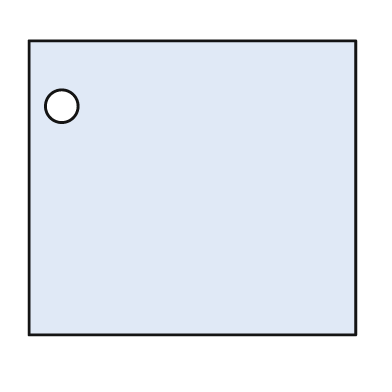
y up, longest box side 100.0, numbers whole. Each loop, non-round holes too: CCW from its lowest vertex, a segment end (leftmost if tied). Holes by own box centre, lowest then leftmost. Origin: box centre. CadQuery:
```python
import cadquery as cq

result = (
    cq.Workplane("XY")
    .moveTo(-50.0, -45.0)
    .lineTo(50.0, -45.0)
    .lineTo(50.0, 45.0)
    .lineTo(-50.0, 45.0)
    .close()
    .moveTo(-40.0, 25.0)
    .circle(5.0)
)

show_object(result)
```